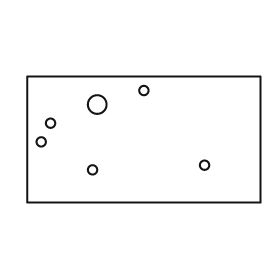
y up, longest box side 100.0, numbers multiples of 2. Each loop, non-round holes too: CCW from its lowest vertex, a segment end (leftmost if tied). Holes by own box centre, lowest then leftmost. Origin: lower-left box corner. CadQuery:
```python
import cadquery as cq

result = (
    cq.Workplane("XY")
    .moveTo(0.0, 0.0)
    .lineTo(100.0, 0.0)
    .lineTo(100.0, 54.0)
    .lineTo(0.0, 54.0)
    .close()
    .moveTo(28.0, 14.0)
    .circle(2.0)
    .moveTo(76.0, 16.0)
    .circle(2.0)
    .moveTo(6.0, 26.0)
    .circle(2.0)
    .moveTo(10.0, 34.0)
    .circle(2.0)
    .moveTo(30.0, 42.0)
    .circle(4.0)
    .moveTo(50.0, 48.0)
    .circle(2.0)
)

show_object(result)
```